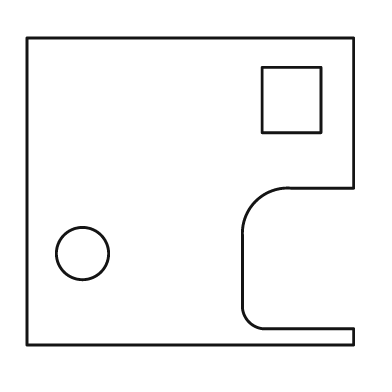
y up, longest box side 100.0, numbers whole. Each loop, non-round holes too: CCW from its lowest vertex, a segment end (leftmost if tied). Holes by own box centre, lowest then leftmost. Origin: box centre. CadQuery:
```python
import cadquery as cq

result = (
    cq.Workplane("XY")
    .moveTo(-50.0, -47.0)
    .lineTo(50.0, -47.0)
    .lineTo(50.0, -42.0)
    .lineTo(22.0, -42.0)
    .threePointArc((18.0, -40.0), (16.0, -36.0))
    .lineTo(16.0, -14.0)
    .threePointArc((20.0, -3.0), (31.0, 1.0))
    .lineTo(50.0, 1.0)
    .lineTo(50.0, 47.0)
    .lineTo(-50.0, 47.0)
    .close()
    .moveTo(-33.0, -19.0)
    .circle(8.0)
    .moveTo(22.0, 18.0)
    .lineTo(40.0, 18.0)
    .lineTo(40.0, 38.0)
    .lineTo(22.0, 38.0)
    .close()
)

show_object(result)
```